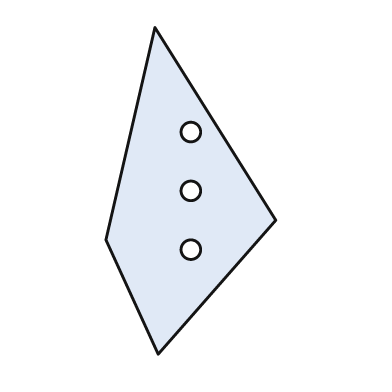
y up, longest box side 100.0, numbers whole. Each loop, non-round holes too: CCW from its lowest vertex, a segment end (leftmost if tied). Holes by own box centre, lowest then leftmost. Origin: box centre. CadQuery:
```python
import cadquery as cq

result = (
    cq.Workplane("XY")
    .moveTo(-10.0, -50.0)
    .lineTo(26.0, -9.0)
    .lineTo(-11.0, 50.0)
    .lineTo(-26.0, -15.0)
    .close()
    .moveTo(0.0, -18.0)
    .circle(3.0)
    .moveTo(0.0, 0.0)
    .circle(3.0)
    .moveTo(0.0, 18.0)
    .circle(3.0)
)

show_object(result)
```